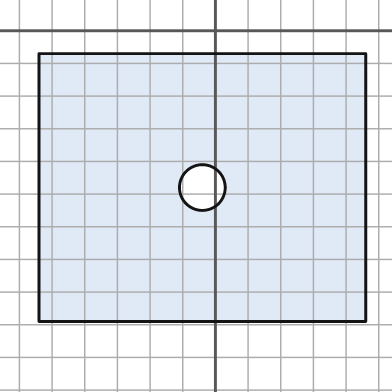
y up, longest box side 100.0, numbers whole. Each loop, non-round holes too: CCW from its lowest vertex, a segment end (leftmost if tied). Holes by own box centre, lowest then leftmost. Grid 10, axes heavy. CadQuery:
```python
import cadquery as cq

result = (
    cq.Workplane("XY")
    .moveTo(-54.0, -89.0)
    .lineTo(46.0, -89.0)
    .lineTo(46.0, -7.0)
    .lineTo(-54.0, -7.0)
    .close()
    .moveTo(-4.0, -48.0)
    .circle(7.0)
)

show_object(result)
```